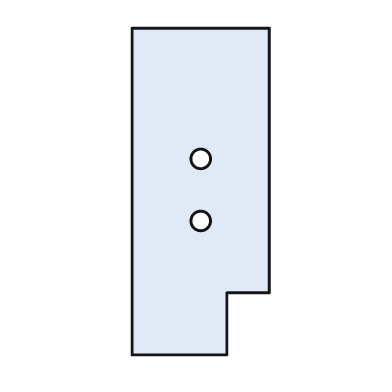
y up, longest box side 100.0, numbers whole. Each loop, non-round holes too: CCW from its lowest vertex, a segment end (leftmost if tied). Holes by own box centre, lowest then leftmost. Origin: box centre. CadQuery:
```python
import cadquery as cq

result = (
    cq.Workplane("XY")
    .moveTo(-21.0, -50.0)
    .lineTo(8.0, -50.0)
    .lineTo(8.0, -31.0)
    .lineTo(21.0, -31.0)
    .lineTo(21.0, 50.0)
    .lineTo(-21.0, 50.0)
    .close()
    .moveTo(0.0, -9.0)
    .circle(3.0)
    .moveTo(0.0, 10.0)
    .circle(3.0)
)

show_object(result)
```